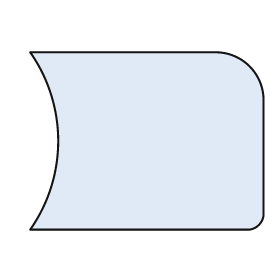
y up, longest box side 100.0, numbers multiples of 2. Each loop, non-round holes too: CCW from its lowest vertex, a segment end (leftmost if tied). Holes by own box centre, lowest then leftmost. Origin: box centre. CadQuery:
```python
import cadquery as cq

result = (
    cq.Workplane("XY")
    .moveTo(-50.0, -38.0)
    .lineTo(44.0, -38.0)
    .threePointArc((48.0, -36.0), (50.0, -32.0))
    .lineTo(50.0, 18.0)
    .threePointArc((44.0, 32.0), (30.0, 38.0))
    .lineTo(-50.0, 38.0)
    .threePointArc((-38.0, 0.0), (-50.0, -38.0))
    .close()
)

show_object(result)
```